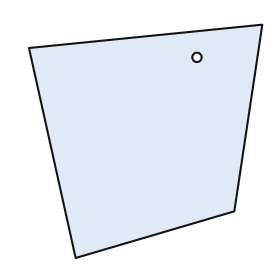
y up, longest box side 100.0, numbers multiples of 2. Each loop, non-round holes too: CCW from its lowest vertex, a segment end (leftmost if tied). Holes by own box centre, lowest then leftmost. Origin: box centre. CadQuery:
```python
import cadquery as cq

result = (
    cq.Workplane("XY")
    .moveTo(-30.0, -50.0)
    .lineTo(38.0, -30.0)
    .lineTo(50.0, 50.0)
    .lineTo(-50.0, 40.0)
    .close()
    .moveTo(22.0, 36.0)
    .circle(2.0)
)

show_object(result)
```